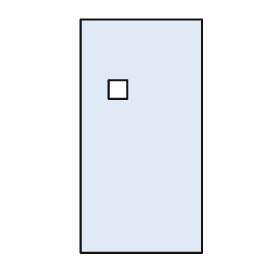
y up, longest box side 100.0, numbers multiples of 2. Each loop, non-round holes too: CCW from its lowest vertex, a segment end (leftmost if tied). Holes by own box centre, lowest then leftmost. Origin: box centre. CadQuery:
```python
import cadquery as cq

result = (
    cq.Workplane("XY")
    .moveTo(-26.0, -50.0)
    .lineTo(26.0, -50.0)
    .lineTo(26.0, 50.0)
    .lineTo(-26.0, 50.0)
    .close()
    .moveTo(-14.0, 16.0)
    .lineTo(-6.0, 16.0)
    .lineTo(-6.0, 24.0)
    .lineTo(-14.0, 24.0)
    .close()
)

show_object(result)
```